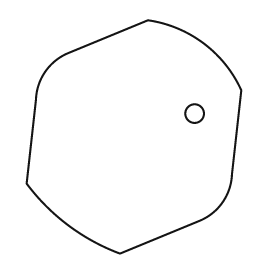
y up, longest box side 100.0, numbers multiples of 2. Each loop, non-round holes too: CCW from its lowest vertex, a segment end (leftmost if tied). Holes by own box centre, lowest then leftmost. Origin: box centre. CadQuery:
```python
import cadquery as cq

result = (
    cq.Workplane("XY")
    .moveTo(-6.0, -50.0)
    .lineTo(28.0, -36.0)
    .threePointArc((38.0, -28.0), (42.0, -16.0))
    .lineTo(46.0, 20.0)
    .threePointArc((30.0, 40.0), (6.0, 50.0))
    .lineTo(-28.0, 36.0)
    .threePointArc((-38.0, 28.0), (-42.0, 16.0))
    .lineTo(-46.0, -20.0)
    .threePointArc((-28.0, -38.0), (-6.0, -50.0))
    .close()
    .moveTo(26.0, 10.0)
    .circle(4.0)
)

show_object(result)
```